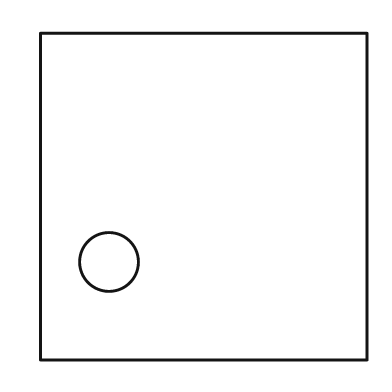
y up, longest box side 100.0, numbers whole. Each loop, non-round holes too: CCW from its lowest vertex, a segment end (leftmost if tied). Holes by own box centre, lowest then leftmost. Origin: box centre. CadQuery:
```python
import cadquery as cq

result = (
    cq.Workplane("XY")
    .moveTo(-50.0, -50.0)
    .lineTo(50.0, -50.0)
    .lineTo(50.0, 50.0)
    .lineTo(-50.0, 50.0)
    .close()
    .moveTo(-29.0, -20.0)
    .circle(9.0)
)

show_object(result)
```